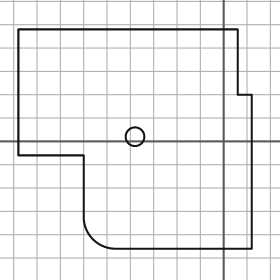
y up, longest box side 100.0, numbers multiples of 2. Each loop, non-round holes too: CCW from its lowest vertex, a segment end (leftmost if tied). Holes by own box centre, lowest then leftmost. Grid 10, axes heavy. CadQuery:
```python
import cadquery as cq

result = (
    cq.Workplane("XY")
    .moveTo(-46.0, -46.0)
    .lineTo(12.0, -46.0)
    .lineTo(12.0, 20.0)
    .lineTo(6.0, 20.0)
    .lineTo(6.0, 48.0)
    .lineTo(-88.0, 48.0)
    .lineTo(-88.0, -6.0)
    .lineTo(-60.0, -6.0)
    .lineTo(-60.0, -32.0)
    .threePointArc((-56.0, -42.0), (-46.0, -46.0))
    .close()
    .moveTo(-38.0, 2.0)
    .circle(4.0)
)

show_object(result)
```